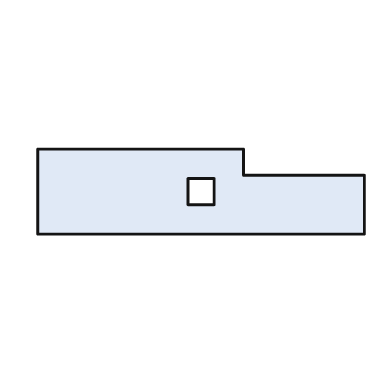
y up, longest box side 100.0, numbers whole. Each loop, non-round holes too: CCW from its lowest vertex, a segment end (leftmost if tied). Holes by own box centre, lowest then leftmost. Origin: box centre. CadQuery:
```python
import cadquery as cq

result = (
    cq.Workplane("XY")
    .moveTo(-50.0, -13.0)
    .lineTo(50.0, -13.0)
    .lineTo(50.0, 5.0)
    .lineTo(13.0, 5.0)
    .lineTo(13.0, 13.0)
    .lineTo(-50.0, 13.0)
    .close()
    .moveTo(-4.0, -4.0)
    .lineTo(4.0, -4.0)
    .lineTo(4.0, 4.0)
    .lineTo(-4.0, 4.0)
    .close()
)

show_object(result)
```